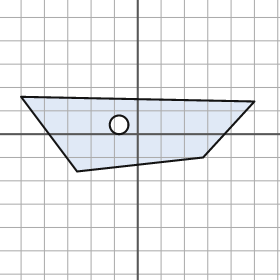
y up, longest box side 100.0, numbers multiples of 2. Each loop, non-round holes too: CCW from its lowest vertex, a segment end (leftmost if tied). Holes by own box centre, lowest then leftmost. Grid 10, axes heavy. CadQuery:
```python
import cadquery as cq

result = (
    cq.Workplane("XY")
    .moveTo(-26.0, -16.0)
    .lineTo(28.0, -10.0)
    .lineTo(50.0, 14.0)
    .lineTo(-50.0, 16.0)
    .close()
    .moveTo(-8.0, 4.0)
    .circle(4.0)
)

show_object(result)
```